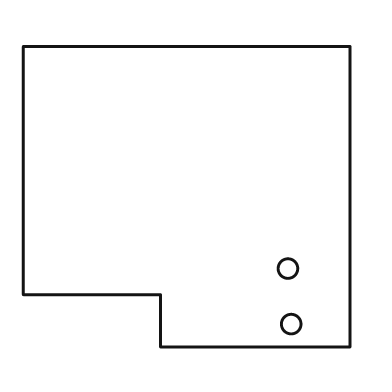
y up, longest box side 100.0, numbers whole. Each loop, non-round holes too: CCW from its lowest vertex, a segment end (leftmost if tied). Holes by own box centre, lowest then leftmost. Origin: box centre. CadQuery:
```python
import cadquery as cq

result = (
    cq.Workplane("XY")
    .moveTo(-8.0, -46.0)
    .lineTo(50.0, -46.0)
    .lineTo(50.0, 46.0)
    .lineTo(-50.0, 46.0)
    .lineTo(-50.0, -30.0)
    .lineTo(-8.0, -30.0)
    .close()
    .moveTo(32.0, -39.0)
    .circle(3.0)
    .moveTo(31.0, -22.0)
    .circle(3.0)
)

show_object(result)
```